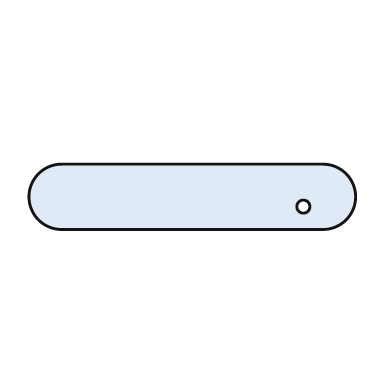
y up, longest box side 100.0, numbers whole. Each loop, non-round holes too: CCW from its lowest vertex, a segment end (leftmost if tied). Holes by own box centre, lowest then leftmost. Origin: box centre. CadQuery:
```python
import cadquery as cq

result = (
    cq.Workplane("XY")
    .moveTo(-40.0, -10.0)
    .lineTo(40.0, -10.0)
    .threePointArc((50.0, 0.0), (40.0, 10.0))
    .lineTo(-40.0, 10.0)
    .threePointArc((-50.0, 0.0), (-40.0, -10.0))
    .close()
    .moveTo(34.0, -3.0)
    .circle(2.0)
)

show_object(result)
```